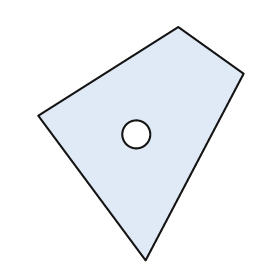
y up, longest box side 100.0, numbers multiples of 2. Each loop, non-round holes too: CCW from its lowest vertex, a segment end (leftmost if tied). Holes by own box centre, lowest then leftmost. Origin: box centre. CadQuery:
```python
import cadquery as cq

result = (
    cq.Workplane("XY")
    .moveTo(2.0, -50.0)
    .lineTo(44.0, 30.0)
    .lineTo(16.0, 50.0)
    .lineTo(-44.0, 12.0)
    .close()
    .moveTo(-2.0, 4.0)
    .circle(6.0)
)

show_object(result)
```